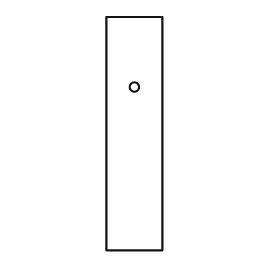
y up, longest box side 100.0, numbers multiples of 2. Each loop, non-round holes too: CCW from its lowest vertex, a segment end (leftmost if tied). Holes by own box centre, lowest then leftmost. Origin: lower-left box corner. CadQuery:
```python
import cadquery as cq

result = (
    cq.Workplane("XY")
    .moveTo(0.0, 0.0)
    .lineTo(24.0, 0.0)
    .lineTo(24.0, 100.0)
    .lineTo(0.0, 100.0)
    .close()
    .moveTo(12.0, 70.0)
    .circle(2.0)
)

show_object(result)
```